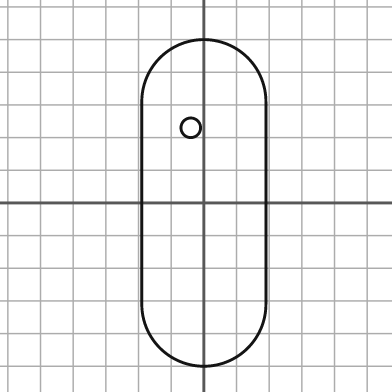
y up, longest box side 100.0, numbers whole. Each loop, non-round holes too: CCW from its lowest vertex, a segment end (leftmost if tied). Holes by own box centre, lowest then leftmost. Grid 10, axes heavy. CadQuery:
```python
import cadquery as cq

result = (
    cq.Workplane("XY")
    .moveTo(-19.0, -31.0)
    .threePointArc((0.0, -50.0), (19.0, -31.0))
    .lineTo(19.0, 31.0)
    .threePointArc((0.0, 50.0), (-19.0, 31.0))
    .close()
    .moveTo(-4.0, 23.0)
    .circle(3.0)
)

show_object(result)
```